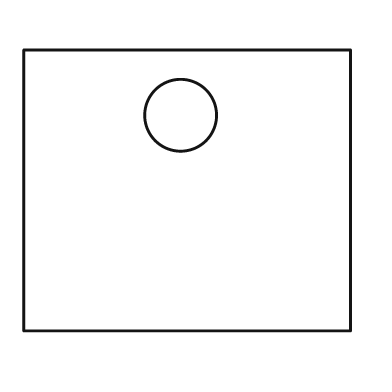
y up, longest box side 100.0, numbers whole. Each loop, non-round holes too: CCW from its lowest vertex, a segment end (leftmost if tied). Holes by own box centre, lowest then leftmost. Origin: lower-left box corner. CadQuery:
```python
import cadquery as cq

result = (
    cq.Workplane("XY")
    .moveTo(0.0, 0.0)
    .lineTo(100.0, 0.0)
    .lineTo(100.0, 86.0)
    .lineTo(0.0, 86.0)
    .close()
    .moveTo(48.0, 66.0)
    .circle(11.0)
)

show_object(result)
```